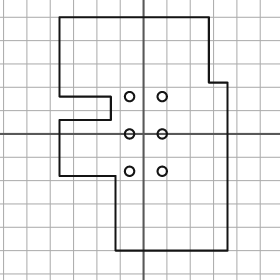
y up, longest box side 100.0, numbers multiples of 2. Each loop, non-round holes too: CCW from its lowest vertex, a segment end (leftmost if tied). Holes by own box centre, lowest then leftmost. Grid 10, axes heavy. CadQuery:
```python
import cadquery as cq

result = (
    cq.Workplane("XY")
    .moveTo(-12.0, -50.0)
    .lineTo(36.0, -50.0)
    .lineTo(36.0, 22.0)
    .lineTo(28.0, 22.0)
    .lineTo(28.0, 50.0)
    .lineTo(-36.0, 50.0)
    .lineTo(-36.0, 16.0)
    .lineTo(-14.0, 16.0)
    .lineTo(-14.0, 6.0)
    .lineTo(-36.0, 6.0)
    .lineTo(-36.0, -18.0)
    .lineTo(-12.0, -18.0)
    .close()
    .moveTo(-6.0, -16.0)
    .circle(2.0)
    .moveTo(8.0, -16.0)
    .circle(2.0)
    .moveTo(-6.0, 0.0)
    .circle(2.0)
    .moveTo(8.0, 0.0)
    .circle(2.0)
    .moveTo(-6.0, 16.0)
    .circle(2.0)
    .moveTo(8.0, 16.0)
    .circle(2.0)
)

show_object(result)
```